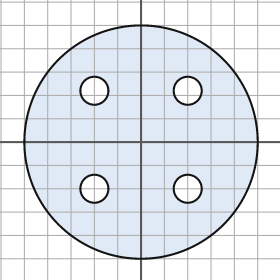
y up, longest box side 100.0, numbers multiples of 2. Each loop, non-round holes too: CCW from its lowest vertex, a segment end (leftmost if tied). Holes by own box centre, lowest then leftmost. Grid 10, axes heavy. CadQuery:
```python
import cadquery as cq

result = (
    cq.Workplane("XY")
    .moveTo(0.0, 0.0)
    .circle(50.0)
    .moveTo(-20.0, -20.0)
    .circle(6.0)
    .moveTo(20.0, -20.0)
    .circle(6.0)
    .moveTo(-20.0, 22.0)
    .circle(6.0)
    .moveTo(20.0, 22.0)
    .circle(6.0)
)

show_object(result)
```